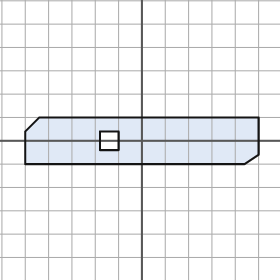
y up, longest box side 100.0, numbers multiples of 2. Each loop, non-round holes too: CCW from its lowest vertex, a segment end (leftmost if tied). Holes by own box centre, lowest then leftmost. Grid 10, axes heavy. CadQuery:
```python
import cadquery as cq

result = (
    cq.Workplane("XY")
    .moveTo(-50.0, -10.0)
    .lineTo(44.0, -10.0)
    .lineTo(50.0, -6.0)
    .lineTo(50.0, 10.0)
    .lineTo(-44.0, 10.0)
    .lineTo(-50.0, 4.0)
    .close()
    .moveTo(-18.0, -4.0)
    .lineTo(-10.0, -4.0)
    .lineTo(-10.0, 4.0)
    .lineTo(-18.0, 4.0)
    .close()
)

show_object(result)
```